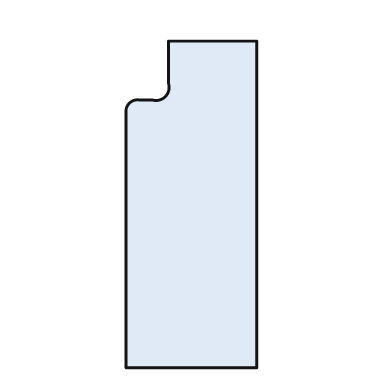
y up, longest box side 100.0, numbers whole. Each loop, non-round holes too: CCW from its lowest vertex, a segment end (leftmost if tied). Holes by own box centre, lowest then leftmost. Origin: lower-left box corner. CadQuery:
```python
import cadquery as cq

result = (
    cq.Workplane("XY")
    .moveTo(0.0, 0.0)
    .lineTo(40.0, 0.0)
    .lineTo(40.0, 100.0)
    .lineTo(13.0, 100.0)
    .lineTo(13.0, 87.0)
    .threePointArc((12.0, 83.0), (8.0, 82.0))
    .lineTo(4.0, 82.0)
    .threePointArc((1.0, 81.0), (0.0, 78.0))
    .close()
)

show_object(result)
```